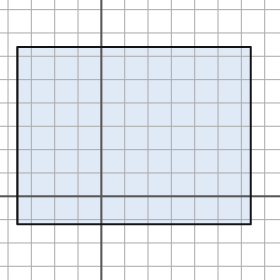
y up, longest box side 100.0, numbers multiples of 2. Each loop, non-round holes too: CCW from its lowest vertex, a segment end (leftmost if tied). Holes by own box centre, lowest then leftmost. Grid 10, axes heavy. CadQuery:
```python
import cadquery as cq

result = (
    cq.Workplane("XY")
    .moveTo(-36.0, -12.0)
    .lineTo(64.0, -12.0)
    .lineTo(64.0, 64.0)
    .lineTo(-36.0, 64.0)
    .close()
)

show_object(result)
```